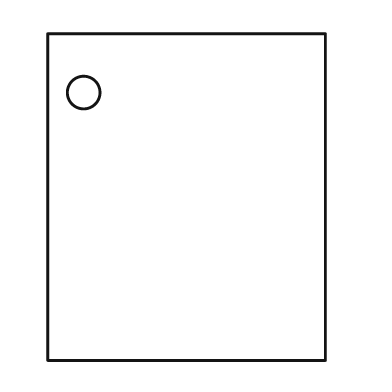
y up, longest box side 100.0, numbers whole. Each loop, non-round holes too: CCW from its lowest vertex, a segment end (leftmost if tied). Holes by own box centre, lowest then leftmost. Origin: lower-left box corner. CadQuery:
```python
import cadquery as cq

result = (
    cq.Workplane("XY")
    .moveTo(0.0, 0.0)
    .lineTo(85.0, 0.0)
    .lineTo(85.0, 100.0)
    .lineTo(0.0, 100.0)
    .close()
    .moveTo(11.0, 82.0)
    .circle(5.0)
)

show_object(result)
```